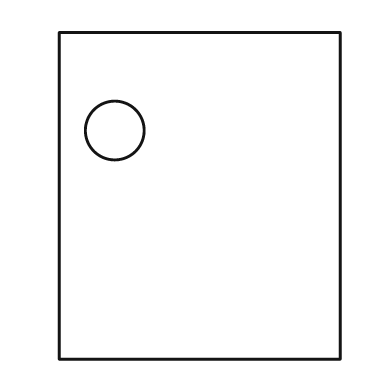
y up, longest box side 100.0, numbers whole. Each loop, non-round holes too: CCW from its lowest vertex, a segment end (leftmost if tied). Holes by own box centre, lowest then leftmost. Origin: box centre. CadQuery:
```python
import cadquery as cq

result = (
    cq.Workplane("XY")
    .moveTo(-43.0, -50.0)
    .lineTo(43.0, -50.0)
    .lineTo(43.0, 50.0)
    .lineTo(-43.0, 50.0)
    .close()
    .moveTo(-26.0, 20.0)
    .circle(9.0)
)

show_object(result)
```